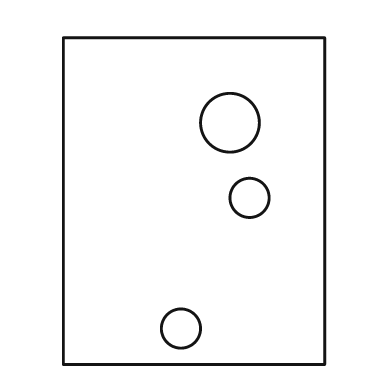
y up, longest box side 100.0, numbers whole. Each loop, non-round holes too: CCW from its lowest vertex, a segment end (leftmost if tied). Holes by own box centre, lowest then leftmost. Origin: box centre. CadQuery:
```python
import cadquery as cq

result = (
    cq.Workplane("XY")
    .moveTo(-40.0, -50.0)
    .lineTo(40.0, -50.0)
    .lineTo(40.0, 50.0)
    .lineTo(-40.0, 50.0)
    .close()
    .moveTo(-4.0, -39.0)
    .circle(6.0)
    .moveTo(17.0, 1.0)
    .circle(6.0)
    .moveTo(11.0, 24.0)
    .circle(9.0)
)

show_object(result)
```